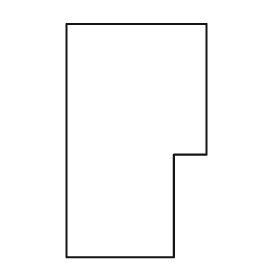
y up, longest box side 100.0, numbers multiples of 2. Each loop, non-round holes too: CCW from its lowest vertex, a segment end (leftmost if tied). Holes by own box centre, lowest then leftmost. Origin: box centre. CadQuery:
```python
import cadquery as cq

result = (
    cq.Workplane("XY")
    .moveTo(-30.0, -50.0)
    .lineTo(16.0, -50.0)
    .lineTo(16.0, -6.0)
    .lineTo(30.0, -6.0)
    .lineTo(30.0, 50.0)
    .lineTo(-30.0, 50.0)
    .close()
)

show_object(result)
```